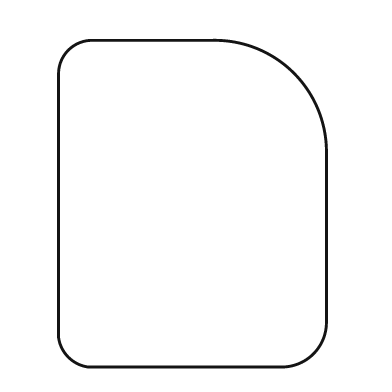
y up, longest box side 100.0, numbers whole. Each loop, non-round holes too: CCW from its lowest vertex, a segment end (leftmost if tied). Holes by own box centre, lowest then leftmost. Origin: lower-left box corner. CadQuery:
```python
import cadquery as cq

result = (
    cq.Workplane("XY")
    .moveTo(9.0, 0.0)
    .lineTo(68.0, 0.0)
    .threePointArc((78.0, 4.0), (82.0, 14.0))
    .lineTo(82.0, 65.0)
    .threePointArc((72.0, 90.0), (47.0, 100.0))
    .lineTo(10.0, 100.0)
    .threePointArc((3.0, 97.0), (0.0, 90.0))
    .lineTo(0.0, 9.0)
    .threePointArc((3.0, 3.0), (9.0, 0.0))
    .close()
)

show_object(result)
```